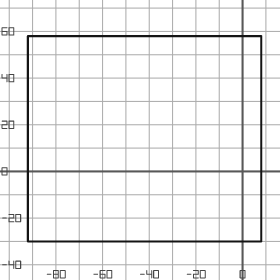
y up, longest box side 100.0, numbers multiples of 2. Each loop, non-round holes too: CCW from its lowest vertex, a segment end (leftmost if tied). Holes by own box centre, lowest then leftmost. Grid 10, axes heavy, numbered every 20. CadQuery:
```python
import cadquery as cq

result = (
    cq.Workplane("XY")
    .moveTo(-92.0, -30.0)
    .lineTo(8.0, -30.0)
    .lineTo(8.0, 58.0)
    .lineTo(-92.0, 58.0)
    .close()
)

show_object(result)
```